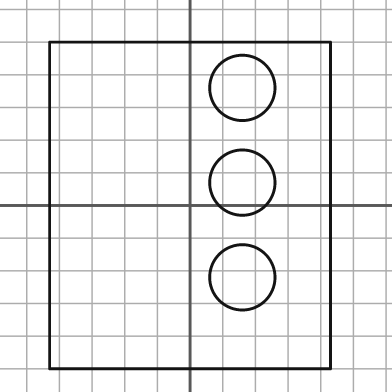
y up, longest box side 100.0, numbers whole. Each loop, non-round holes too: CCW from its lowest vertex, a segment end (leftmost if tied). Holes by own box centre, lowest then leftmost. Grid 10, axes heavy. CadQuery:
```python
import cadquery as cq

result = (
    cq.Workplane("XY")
    .moveTo(-43.0, -50.0)
    .lineTo(43.0, -50.0)
    .lineTo(43.0, 50.0)
    .lineTo(-43.0, 50.0)
    .close()
    .moveTo(16.0, -22.0)
    .circle(10.0)
    .moveTo(16.0, 7.0)
    .circle(10.0)
    .moveTo(16.0, 36.0)
    .circle(10.0)
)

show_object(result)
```